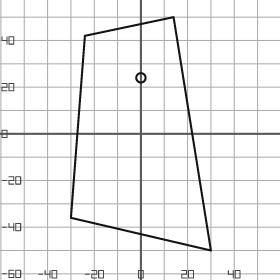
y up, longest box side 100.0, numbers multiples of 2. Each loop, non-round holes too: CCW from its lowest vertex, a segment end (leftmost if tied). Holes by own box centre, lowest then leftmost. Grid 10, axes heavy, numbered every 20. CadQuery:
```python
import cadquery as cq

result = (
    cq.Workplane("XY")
    .moveTo(30.0, -50.0)
    .lineTo(14.0, 50.0)
    .lineTo(-24.0, 42.0)
    .lineTo(-30.0, -36.0)
    .close()
    .moveTo(0.0, 24.0)
    .circle(2.0)
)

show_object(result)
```